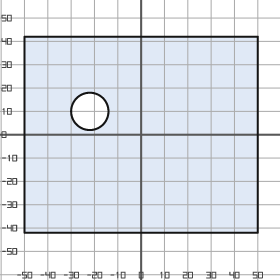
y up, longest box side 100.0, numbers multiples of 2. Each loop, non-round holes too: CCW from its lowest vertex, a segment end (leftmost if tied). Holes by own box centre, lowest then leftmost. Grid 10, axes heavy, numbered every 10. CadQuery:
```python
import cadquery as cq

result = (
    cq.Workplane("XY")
    .moveTo(-50.0, -42.0)
    .lineTo(50.0, -42.0)
    .lineTo(50.0, 42.0)
    .lineTo(-50.0, 42.0)
    .close()
    .moveTo(-22.0, 10.0)
    .circle(8.0)
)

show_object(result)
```